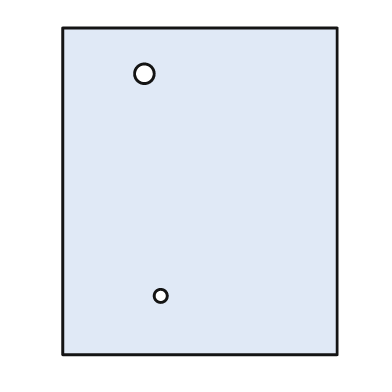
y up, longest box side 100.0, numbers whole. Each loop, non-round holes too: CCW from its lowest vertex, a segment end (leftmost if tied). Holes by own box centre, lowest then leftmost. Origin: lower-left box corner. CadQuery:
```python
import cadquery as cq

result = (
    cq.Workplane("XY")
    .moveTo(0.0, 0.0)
    .lineTo(84.0, 0.0)
    .lineTo(84.0, 100.0)
    .lineTo(0.0, 100.0)
    .close()
    .moveTo(30.0, 18.0)
    .circle(2.0)
    .moveTo(25.0, 86.0)
    .circle(3.0)
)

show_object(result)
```